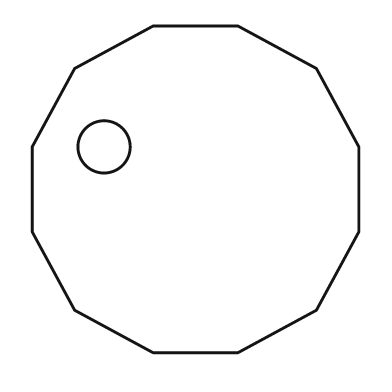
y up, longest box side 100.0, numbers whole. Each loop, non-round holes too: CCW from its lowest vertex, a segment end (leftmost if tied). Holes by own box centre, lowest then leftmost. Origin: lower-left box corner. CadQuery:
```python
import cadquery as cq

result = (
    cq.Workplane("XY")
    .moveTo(37.0, 0.0)
    .lineTo(63.0, 0.0)
    .lineTo(87.0, 13.0)
    .lineTo(100.0, 37.0)
    .lineTo(100.0, 63.0)
    .lineTo(87.0, 87.0)
    .lineTo(63.0, 100.0)
    .lineTo(37.0, 100.0)
    .lineTo(13.0, 87.0)
    .lineTo(0.0, 63.0)
    .lineTo(0.0, 37.0)
    .lineTo(13.0, 13.0)
    .close()
    .moveTo(22.0, 63.0)
    .circle(8.0)
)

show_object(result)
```